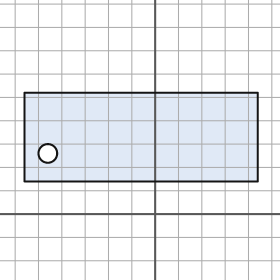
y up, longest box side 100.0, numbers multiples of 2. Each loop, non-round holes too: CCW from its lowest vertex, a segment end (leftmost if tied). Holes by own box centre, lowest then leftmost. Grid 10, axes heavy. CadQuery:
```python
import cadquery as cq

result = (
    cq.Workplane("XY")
    .moveTo(-56.0, 14.0)
    .lineTo(44.0, 14.0)
    .lineTo(44.0, 52.0)
    .lineTo(-56.0, 52.0)
    .close()
    .moveTo(-46.0, 26.0)
    .circle(4.0)
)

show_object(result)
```